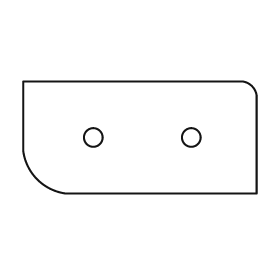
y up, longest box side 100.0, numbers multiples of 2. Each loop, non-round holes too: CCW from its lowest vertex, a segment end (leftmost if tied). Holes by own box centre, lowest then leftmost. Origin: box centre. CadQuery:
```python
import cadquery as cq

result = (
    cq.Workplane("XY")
    .moveTo(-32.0, -24.0)
    .lineTo(50.0, -24.0)
    .lineTo(50.0, 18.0)
    .threePointArc((48.0, 22.0), (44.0, 24.0))
    .lineTo(-50.0, 24.0)
    .lineTo(-50.0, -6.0)
    .threePointArc((-44.0, -18.0), (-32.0, -24.0))
    .close()
    .moveTo(-20.0, 0.0)
    .circle(4.0)
    .moveTo(22.0, 0.0)
    .circle(4.0)
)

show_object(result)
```